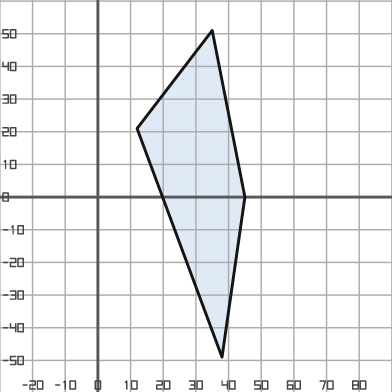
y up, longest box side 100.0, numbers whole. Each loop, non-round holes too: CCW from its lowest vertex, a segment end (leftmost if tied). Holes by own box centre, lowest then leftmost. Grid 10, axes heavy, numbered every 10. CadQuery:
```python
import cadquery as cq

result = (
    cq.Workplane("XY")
    .moveTo(38.0, -49.0)
    .lineTo(45.0, 0.0)
    .lineTo(35.0, 51.0)
    .lineTo(12.0, 21.0)
    .close()
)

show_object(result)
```